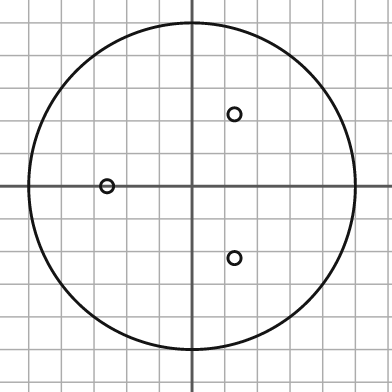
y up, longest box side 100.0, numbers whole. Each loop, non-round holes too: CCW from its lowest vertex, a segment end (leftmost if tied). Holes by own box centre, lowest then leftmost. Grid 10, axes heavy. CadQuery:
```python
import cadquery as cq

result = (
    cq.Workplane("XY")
    .moveTo(0.0, 0.0)
    .circle(50.0)
    .moveTo(13.0, -22.0)
    .circle(2.0)
    .moveTo(-26.0, 0.0)
    .circle(2.0)
    .moveTo(13.0, 22.0)
    .circle(2.0)
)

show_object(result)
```